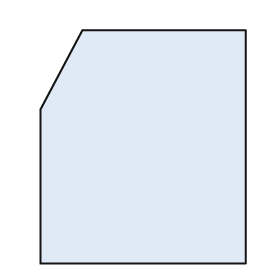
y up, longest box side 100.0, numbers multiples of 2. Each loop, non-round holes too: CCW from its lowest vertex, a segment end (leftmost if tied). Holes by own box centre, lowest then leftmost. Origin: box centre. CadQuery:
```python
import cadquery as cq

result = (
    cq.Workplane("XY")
    .moveTo(-44.0, -50.0)
    .lineTo(44.0, -50.0)
    .lineTo(44.0, 50.0)
    .lineTo(-26.0, 50.0)
    .lineTo(-44.0, 16.0)
    .close()
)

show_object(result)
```